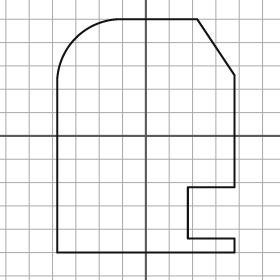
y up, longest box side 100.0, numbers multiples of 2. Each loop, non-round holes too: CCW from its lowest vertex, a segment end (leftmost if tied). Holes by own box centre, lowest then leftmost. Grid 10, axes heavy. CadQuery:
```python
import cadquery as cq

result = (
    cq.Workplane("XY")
    .moveTo(-38.0, -50.0)
    .lineTo(38.0, -50.0)
    .lineTo(38.0, -44.0)
    .lineTo(18.0, -44.0)
    .lineTo(18.0, -22.0)
    .lineTo(38.0, -22.0)
    .lineTo(38.0, 26.0)
    .lineTo(22.0, 50.0)
    .lineTo(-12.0, 50.0)
    .threePointArc((-30.0, 42.0), (-38.0, 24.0))
    .close()
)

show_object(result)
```